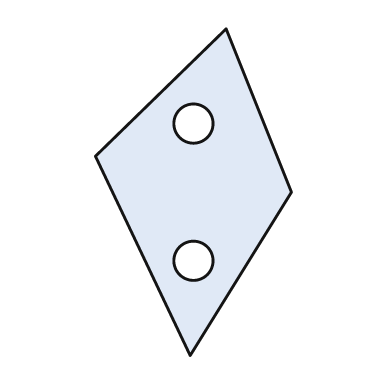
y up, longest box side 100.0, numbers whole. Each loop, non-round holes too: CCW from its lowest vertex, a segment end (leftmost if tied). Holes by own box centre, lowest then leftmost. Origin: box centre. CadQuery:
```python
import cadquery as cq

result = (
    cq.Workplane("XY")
    .moveTo(-1.0, -50.0)
    .lineTo(30.0, 0.0)
    .lineTo(10.0, 50.0)
    .lineTo(-30.0, 11.0)
    .close()
    .moveTo(0.0, -21.0)
    .circle(6.0)
    .moveTo(0.0, 21.0)
    .circle(6.0)
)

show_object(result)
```